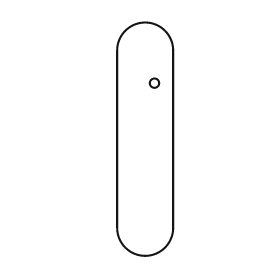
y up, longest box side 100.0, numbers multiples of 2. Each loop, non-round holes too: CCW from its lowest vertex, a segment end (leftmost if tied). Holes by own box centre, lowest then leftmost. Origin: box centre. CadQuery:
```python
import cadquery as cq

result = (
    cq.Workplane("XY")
    .moveTo(-12.0, -38.0)
    .threePointArc((0.0, -50.0), (12.0, -38.0))
    .lineTo(12.0, 38.0)
    .threePointArc((0.0, 50.0), (-12.0, 38.0))
    .close()
    .moveTo(4.0, 24.0)
    .circle(2.0)
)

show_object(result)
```